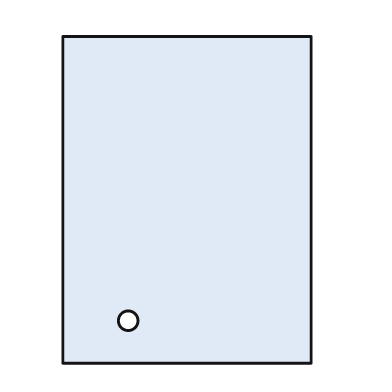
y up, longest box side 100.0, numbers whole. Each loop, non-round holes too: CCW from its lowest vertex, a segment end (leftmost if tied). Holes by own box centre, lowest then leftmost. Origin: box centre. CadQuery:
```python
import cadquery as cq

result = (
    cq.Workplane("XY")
    .moveTo(-38.0, -50.0)
    .lineTo(38.0, -50.0)
    .lineTo(38.0, 50.0)
    .lineTo(-38.0, 50.0)
    .close()
    .moveTo(-18.0, -37.0)
    .circle(3.0)
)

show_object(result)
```